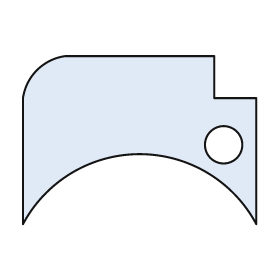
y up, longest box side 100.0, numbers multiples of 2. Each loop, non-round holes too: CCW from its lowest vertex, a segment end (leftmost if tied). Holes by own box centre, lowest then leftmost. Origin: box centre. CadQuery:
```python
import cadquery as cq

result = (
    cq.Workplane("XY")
    .moveTo(-50.0, -36.0)
    .threePointArc((0.0, -6.0), (50.0, -36.0))
    .lineTo(50.0, 18.0)
    .lineTo(32.0, 18.0)
    .lineTo(32.0, 36.0)
    .lineTo(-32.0, 36.0)
    .threePointArc((-44.0, 30.0), (-50.0, 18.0))
    .close()
    .moveTo(36.0, -2.0)
    .circle(8.0)
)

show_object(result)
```